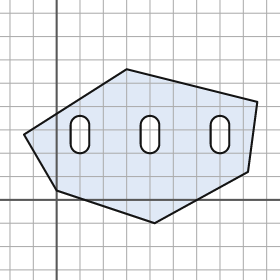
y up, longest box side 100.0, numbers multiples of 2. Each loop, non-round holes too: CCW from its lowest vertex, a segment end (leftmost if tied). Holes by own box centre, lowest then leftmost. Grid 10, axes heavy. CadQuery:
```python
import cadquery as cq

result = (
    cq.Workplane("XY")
    .moveTo(42.0, -10.0)
    .lineTo(82.0, 12.0)
    .lineTo(86.0, 42.0)
    .lineTo(30.0, 56.0)
    .lineTo(-14.0, 28.0)
    .lineTo(0.0, 4.0)
    .close()
    .moveTo(6.0, 24.0)
    .threePointArc((10.0, 20.0), (14.0, 24.0))
    .lineTo(14.0, 32.0)
    .threePointArc((10.0, 36.0), (6.0, 32.0))
    .close()
    .moveTo(36.0, 24.0)
    .threePointArc((40.0, 20.0), (44.0, 24.0))
    .lineTo(44.0, 32.0)
    .threePointArc((40.0, 36.0), (36.0, 32.0))
    .close()
    .moveTo(66.0, 24.0)
    .threePointArc((70.0, 20.0), (74.0, 24.0))
    .lineTo(74.0, 32.0)
    .threePointArc((70.0, 36.0), (66.0, 32.0))
    .close()
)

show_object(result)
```